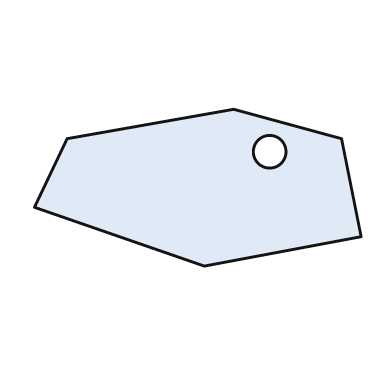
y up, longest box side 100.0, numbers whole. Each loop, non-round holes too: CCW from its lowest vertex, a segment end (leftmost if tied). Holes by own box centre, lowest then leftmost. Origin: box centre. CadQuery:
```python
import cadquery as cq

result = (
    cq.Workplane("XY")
    .moveTo(2.0, -24.0)
    .lineTo(50.0, -15.0)
    .lineTo(44.0, 15.0)
    .lineTo(11.0, 24.0)
    .lineTo(-40.0, 15.0)
    .lineTo(-50.0, -6.0)
    .close()
    .moveTo(22.0, 11.0)
    .circle(5.0)
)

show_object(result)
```